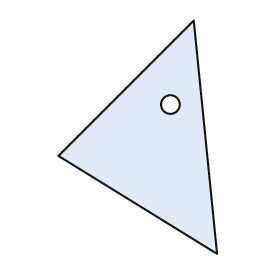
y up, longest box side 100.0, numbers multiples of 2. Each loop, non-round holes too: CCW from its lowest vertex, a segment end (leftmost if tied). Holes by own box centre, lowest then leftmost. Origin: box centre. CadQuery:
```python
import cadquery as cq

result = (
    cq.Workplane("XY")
    .moveTo(34.0, -50.0)
    .lineTo(24.0, 50.0)
    .lineTo(-34.0, -8.0)
    .close()
    .moveTo(14.0, 14.0)
    .circle(4.0)
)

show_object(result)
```